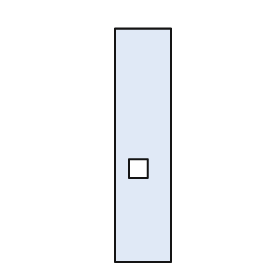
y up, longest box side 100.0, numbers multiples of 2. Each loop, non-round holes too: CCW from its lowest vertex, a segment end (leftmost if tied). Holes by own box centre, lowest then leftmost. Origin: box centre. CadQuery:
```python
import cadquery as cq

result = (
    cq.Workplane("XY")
    .moveTo(-12.0, -50.0)
    .lineTo(12.0, -50.0)
    .lineTo(12.0, 50.0)
    .lineTo(-12.0, 50.0)
    .close()
    .moveTo(-6.0, -14.0)
    .lineTo(2.0, -14.0)
    .lineTo(2.0, -6.0)
    .lineTo(-6.0, -6.0)
    .close()
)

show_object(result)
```